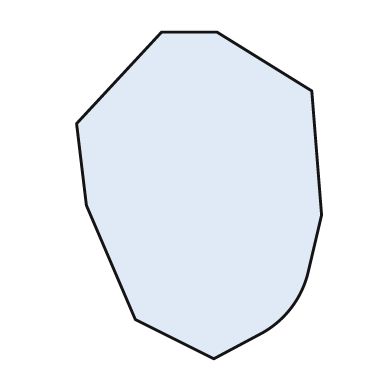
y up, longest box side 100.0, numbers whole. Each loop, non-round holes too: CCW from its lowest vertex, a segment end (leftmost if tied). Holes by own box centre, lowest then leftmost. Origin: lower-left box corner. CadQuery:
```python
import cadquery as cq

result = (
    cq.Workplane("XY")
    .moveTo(42.0, 0.0)
    .lineTo(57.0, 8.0)
    .threePointArc((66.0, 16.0), (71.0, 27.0))
    .lineTo(75.0, 44.0)
    .lineTo(72.0, 82.0)
    .lineTo(43.0, 100.0)
    .lineTo(26.0, 100.0)
    .lineTo(0.0, 72.0)
    .lineTo(3.0, 47.0)
    .lineTo(18.0, 12.0)
    .close()
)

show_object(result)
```